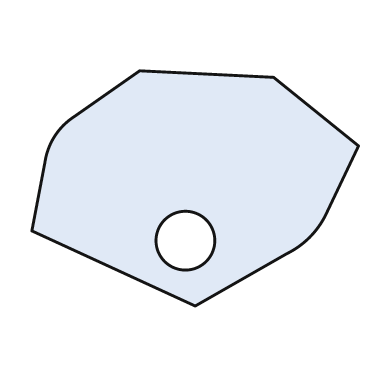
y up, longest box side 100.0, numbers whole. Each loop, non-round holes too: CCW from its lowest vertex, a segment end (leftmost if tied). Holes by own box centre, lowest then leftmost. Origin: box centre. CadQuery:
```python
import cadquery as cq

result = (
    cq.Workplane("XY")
    .moveTo(0.0, -36.0)
    .lineTo(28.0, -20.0)
    .threePointArc((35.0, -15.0), (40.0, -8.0))
    .lineTo(50.0, 13.0)
    .lineTo(24.0, 34.0)
    .lineTo(-17.0, 36.0)
    .lineTo(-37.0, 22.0)
    .threePointArc((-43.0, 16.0), (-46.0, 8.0))
    .lineTo(-50.0, -13.0)
    .close()
    .moveTo(-3.0, -16.0)
    .circle(9.0)
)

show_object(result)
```